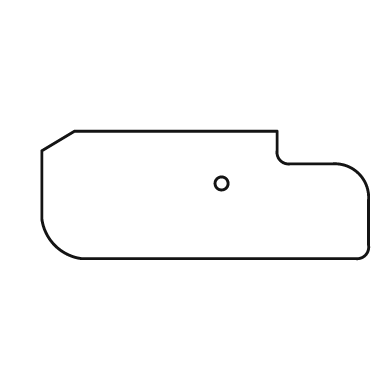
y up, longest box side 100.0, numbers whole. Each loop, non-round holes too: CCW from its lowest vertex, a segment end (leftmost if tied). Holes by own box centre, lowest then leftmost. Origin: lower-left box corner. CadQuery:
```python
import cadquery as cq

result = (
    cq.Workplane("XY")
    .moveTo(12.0, 0.0)
    .lineTo(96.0, 0.0)
    .threePointArc((99.0, 1.0), (100.0, 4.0))
    .lineTo(100.0, 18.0)
    .threePointArc((97.0, 26.0), (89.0, 29.0))
    .lineTo(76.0, 29.0)
    .threePointArc((73.0, 30.0), (72.0, 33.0))
    .lineTo(72.0, 39.0)
    .lineTo(10.0, 39.0)
    .lineTo(0.0, 33.0)
    .lineTo(0.0, 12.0)
    .threePointArc((4.0, 4.0), (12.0, 0.0))
    .close()
    .moveTo(55.0, 23.0)
    .circle(2.0)
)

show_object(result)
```